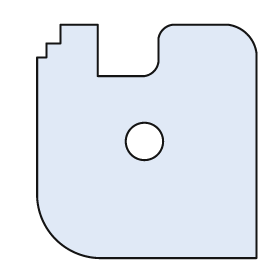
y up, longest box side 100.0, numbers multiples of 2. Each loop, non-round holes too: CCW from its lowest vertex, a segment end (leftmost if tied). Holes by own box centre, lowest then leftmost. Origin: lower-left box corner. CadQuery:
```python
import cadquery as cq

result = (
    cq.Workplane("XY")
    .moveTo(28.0, 0.0)
    .lineTo(94.0, 0.0)
    .lineTo(94.0, 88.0)
    .threePointArc((90.0, 96.0), (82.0, 100.0))
    .lineTo(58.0, 100.0)
    .threePointArc((54.0, 98.0), (52.0, 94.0))
    .lineTo(52.0, 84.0)
    .threePointArc((50.0, 80.0), (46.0, 78.0))
    .lineTo(26.0, 78.0)
    .lineTo(26.0, 100.0)
    .lineTo(10.0, 100.0)
    .lineTo(10.0, 92.0)
    .lineTo(4.0, 92.0)
    .lineTo(4.0, 86.0)
    .lineTo(0.0, 86.0)
    .lineTo(0.0, 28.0)
    .threePointArc((8.0, 8.0), (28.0, 0.0))
    .close()
    .moveTo(46.0, 50.0)
    .circle(8.0)
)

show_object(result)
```